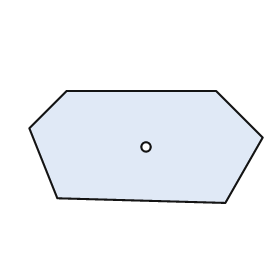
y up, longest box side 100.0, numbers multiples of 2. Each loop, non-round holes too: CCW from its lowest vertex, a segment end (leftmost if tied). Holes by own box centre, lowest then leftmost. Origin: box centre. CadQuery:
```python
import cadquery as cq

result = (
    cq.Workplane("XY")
    .moveTo(34.0, -24.0)
    .lineTo(50.0, 4.0)
    .lineTo(30.0, 24.0)
    .lineTo(-34.0, 24.0)
    .lineTo(-50.0, 8.0)
    .lineTo(-38.0, -22.0)
    .close()
    .moveTo(0.0, 0.0)
    .circle(2.0)
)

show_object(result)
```